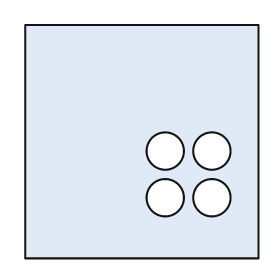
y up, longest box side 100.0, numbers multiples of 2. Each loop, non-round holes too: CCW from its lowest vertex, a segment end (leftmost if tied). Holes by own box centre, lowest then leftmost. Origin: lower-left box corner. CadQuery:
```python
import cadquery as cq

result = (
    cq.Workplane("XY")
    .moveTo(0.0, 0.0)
    .lineTo(100.0, 0.0)
    .lineTo(100.0, 100.0)
    .lineTo(0.0, 100.0)
    .close()
    .moveTo(60.0, 26.0)
    .circle(8.0)
    .moveTo(80.0, 26.0)
    .circle(8.0)
    .moveTo(60.0, 46.0)
    .circle(8.0)
    .moveTo(80.0, 46.0)
    .circle(8.0)
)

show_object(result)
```